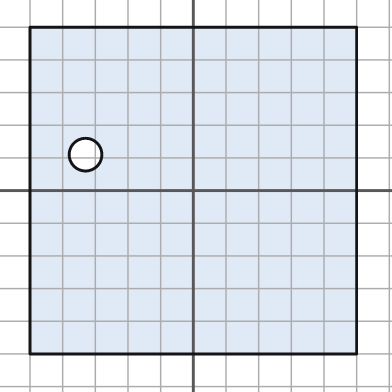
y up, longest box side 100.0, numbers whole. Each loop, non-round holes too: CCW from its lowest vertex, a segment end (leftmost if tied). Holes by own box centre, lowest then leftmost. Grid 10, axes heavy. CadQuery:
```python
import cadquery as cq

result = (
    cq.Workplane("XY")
    .moveTo(-50.0, -50.0)
    .lineTo(50.0, -50.0)
    .lineTo(50.0, 50.0)
    .lineTo(-50.0, 50.0)
    .close()
    .moveTo(-33.0, 11.0)
    .circle(5.0)
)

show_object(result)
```